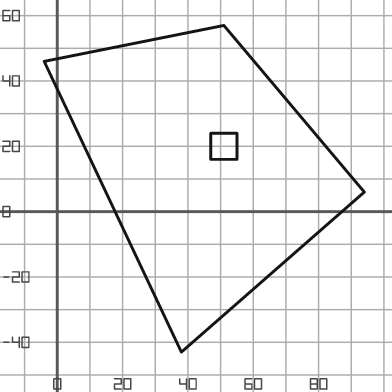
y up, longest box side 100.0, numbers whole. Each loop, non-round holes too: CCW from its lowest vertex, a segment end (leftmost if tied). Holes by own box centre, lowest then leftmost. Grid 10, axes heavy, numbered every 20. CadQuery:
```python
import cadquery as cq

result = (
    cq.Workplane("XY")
    .moveTo(38.0, -43.0)
    .lineTo(94.0, 6.0)
    .lineTo(51.0, 57.0)
    .lineTo(-4.0, 46.0)
    .close()
    .moveTo(47.0, 16.0)
    .lineTo(55.0, 16.0)
    .lineTo(55.0, 24.0)
    .lineTo(47.0, 24.0)
    .close()
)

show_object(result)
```